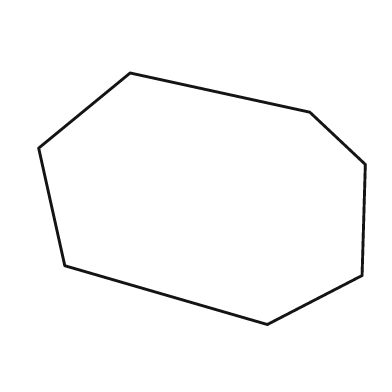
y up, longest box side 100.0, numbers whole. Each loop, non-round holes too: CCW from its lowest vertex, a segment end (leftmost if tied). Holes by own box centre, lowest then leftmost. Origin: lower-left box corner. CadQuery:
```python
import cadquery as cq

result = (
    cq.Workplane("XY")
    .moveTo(70.0, 0.0)
    .lineTo(99.0, 15.0)
    .lineTo(100.0, 49.0)
    .lineTo(83.0, 65.0)
    .lineTo(28.0, 77.0)
    .lineTo(0.0, 54.0)
    .lineTo(8.0, 18.0)
    .close()
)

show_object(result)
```